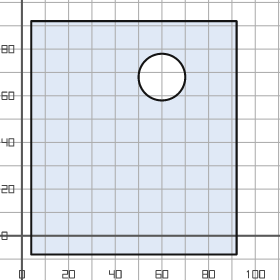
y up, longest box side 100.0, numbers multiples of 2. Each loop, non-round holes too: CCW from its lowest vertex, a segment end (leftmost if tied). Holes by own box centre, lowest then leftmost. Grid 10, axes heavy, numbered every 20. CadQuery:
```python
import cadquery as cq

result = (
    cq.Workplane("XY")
    .moveTo(4.0, -8.0)
    .lineTo(92.0, -8.0)
    .lineTo(92.0, 92.0)
    .lineTo(4.0, 92.0)
    .close()
    .moveTo(60.0, 68.0)
    .circle(10.0)
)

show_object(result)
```